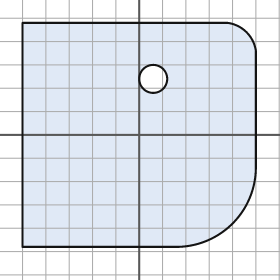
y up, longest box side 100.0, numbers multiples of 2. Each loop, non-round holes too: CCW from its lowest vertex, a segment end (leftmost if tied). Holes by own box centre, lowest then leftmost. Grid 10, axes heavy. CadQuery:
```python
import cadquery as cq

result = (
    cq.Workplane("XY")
    .moveTo(-50.0, -48.0)
    .lineTo(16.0, -48.0)
    .threePointArc((40.0, -38.0), (50.0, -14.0))
    .lineTo(50.0, 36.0)
    .threePointArc((46.0, 44.0), (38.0, 48.0))
    .lineTo(-50.0, 48.0)
    .close()
    .moveTo(6.0, 24.0)
    .circle(6.0)
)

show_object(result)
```